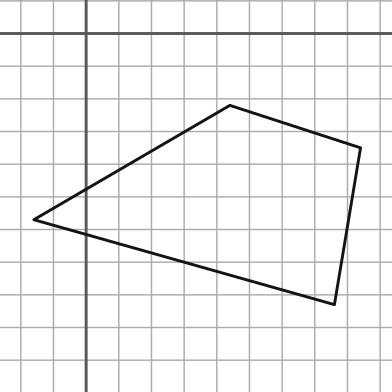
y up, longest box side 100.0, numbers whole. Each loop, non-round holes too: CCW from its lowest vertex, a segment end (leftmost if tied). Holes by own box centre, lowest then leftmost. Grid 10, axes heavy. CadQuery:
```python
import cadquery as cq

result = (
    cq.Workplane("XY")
    .moveTo(76.0, -83.0)
    .lineTo(84.0, -35.0)
    .lineTo(44.0, -22.0)
    .lineTo(-16.0, -57.0)
    .close()
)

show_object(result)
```